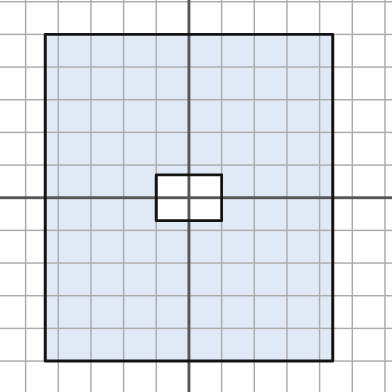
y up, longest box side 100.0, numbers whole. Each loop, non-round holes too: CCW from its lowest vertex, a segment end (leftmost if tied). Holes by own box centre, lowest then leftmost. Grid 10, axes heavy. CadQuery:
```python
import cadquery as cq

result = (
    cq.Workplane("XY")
    .moveTo(-44.0, -50.0)
    .lineTo(44.0, -50.0)
    .lineTo(44.0, 50.0)
    .lineTo(-44.0, 50.0)
    .close()
    .moveTo(-10.0, -7.0)
    .lineTo(10.0, -7.0)
    .lineTo(10.0, 7.0)
    .lineTo(-10.0, 7.0)
    .close()
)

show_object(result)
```